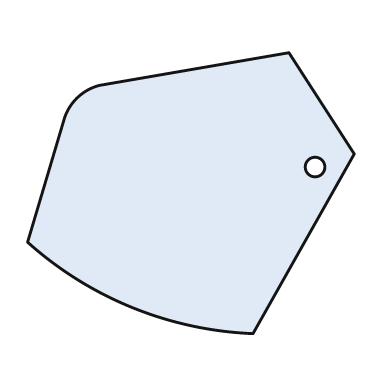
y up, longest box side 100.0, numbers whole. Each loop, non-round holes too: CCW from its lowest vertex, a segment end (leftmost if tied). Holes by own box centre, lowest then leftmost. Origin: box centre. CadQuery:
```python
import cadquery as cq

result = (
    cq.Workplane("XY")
    .moveTo(19.0, -43.0)
    .lineTo(50.0, 12.0)
    .lineTo(30.0, 43.0)
    .lineTo(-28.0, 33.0)
    .threePointArc((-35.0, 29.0), (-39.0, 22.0))
    .lineTo(-50.0, -15.0)
    .threePointArc((-18.0, -35.0), (19.0, -43.0))
    .close()
    .moveTo(38.0, 8.0)
    .circle(3.0)
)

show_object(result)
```